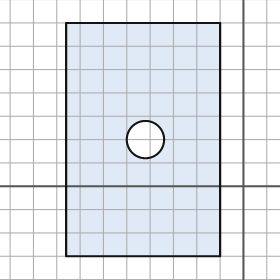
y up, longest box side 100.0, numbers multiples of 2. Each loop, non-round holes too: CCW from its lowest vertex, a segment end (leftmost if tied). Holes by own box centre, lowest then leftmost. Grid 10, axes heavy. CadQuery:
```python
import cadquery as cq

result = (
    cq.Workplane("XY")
    .moveTo(-76.0, -30.0)
    .lineTo(-10.0, -30.0)
    .lineTo(-10.0, 70.0)
    .lineTo(-76.0, 70.0)
    .close()
    .moveTo(-42.0, 20.0)
    .circle(8.0)
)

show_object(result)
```